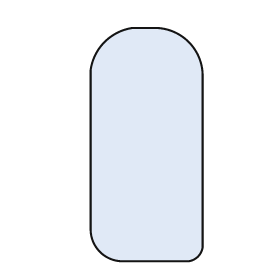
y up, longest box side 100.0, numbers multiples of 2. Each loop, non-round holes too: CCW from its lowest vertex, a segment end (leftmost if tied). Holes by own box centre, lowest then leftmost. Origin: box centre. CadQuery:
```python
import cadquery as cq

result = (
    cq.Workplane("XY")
    .moveTo(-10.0, -50.0)
    .lineTo(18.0, -50.0)
    .threePointArc((22.0, -48.0), (24.0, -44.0))
    .lineTo(24.0, 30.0)
    .threePointArc((18.0, 44.0), (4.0, 50.0))
    .lineTo(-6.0, 50.0)
    .threePointArc((-18.0, 44.0), (-24.0, 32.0))
    .lineTo(-24.0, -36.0)
    .threePointArc((-20.0, -46.0), (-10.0, -50.0))
    .close()
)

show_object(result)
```